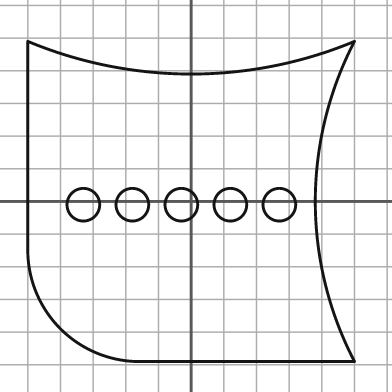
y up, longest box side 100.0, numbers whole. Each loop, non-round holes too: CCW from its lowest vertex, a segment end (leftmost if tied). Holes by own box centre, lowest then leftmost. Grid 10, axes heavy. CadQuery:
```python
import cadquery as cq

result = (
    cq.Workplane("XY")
    .moveTo(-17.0, -49.0)
    .lineTo(50.0, -49.0)
    .threePointArc((38.0, 0.0), (50.0, 49.0))
    .threePointArc((0.0, 39.0), (-50.0, 49.0))
    .lineTo(-50.0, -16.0)
    .threePointArc((-40.0, -39.0), (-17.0, -49.0))
    .close()
    .moveTo(-33.0, -1.0)
    .circle(5.0)
    .moveTo(-18.0, -1.0)
    .circle(5.0)
    .moveTo(-3.0, -1.0)
    .circle(5.0)
    .moveTo(12.0, -1.0)
    .circle(5.0)
    .moveTo(27.0, -1.0)
    .circle(5.0)
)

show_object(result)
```